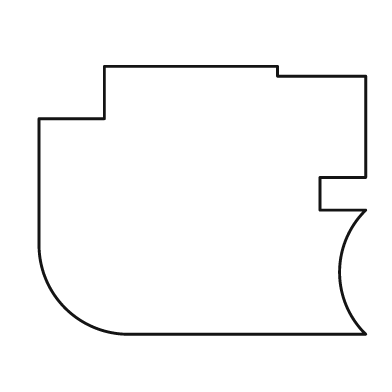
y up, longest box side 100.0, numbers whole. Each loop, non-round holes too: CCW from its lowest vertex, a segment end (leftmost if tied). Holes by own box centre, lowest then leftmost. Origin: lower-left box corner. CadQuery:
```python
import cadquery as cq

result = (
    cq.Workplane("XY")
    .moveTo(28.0, 0.0)
    .lineTo(100.0, 0.0)
    .threePointArc((92.0, 19.0), (100.0, 38.0))
    .lineTo(86.0, 38.0)
    .lineTo(86.0, 48.0)
    .lineTo(100.0, 48.0)
    .lineTo(100.0, 79.0)
    .lineTo(73.0, 79.0)
    .lineTo(73.0, 82.0)
    .lineTo(20.0, 82.0)
    .lineTo(20.0, 66.0)
    .lineTo(0.0, 66.0)
    .lineTo(0.0, 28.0)
    .threePointArc((8.0, 8.0), (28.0, 0.0))
    .close()
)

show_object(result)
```